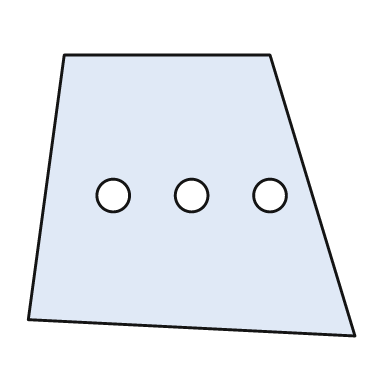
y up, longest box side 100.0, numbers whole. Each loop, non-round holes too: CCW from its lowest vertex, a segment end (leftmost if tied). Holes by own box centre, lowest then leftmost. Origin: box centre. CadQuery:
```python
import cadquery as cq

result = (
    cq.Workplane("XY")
    .moveTo(50.0, -43.0)
    .lineTo(24.0, 43.0)
    .lineTo(-39.0, 43.0)
    .lineTo(-50.0, -38.0)
    .close()
    .moveTo(-24.0, 0.0)
    .circle(5.0)
    .moveTo(0.0, 0.0)
    .circle(5.0)
    .moveTo(24.0, 0.0)
    .circle(5.0)
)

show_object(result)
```